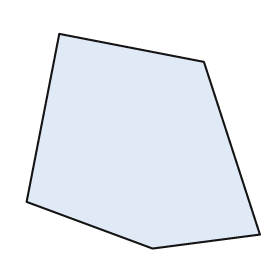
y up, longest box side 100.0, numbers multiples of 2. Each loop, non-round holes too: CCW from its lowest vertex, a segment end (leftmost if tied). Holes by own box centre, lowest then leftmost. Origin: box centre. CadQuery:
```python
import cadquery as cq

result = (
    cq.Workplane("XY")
    .moveTo(4.0, -46.0)
    .lineTo(50.0, -40.0)
    .lineTo(26.0, 34.0)
    .lineTo(-36.0, 46.0)
    .lineTo(-50.0, -26.0)
    .close()
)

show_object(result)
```